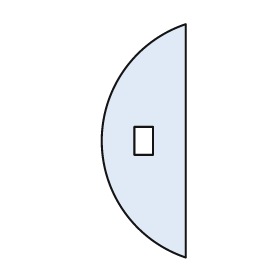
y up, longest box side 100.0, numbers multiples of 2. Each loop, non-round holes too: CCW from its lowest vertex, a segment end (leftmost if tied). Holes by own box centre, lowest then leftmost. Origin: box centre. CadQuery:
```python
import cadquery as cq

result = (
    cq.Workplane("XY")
    .moveTo(18.0, -50.0)
    .lineTo(18.0, 50.0)
    .threePointArc((-18.0, 0.0), (18.0, -50.0))
    .close()
    .moveTo(-4.0, -6.0)
    .lineTo(4.0, -6.0)
    .lineTo(4.0, 6.0)
    .lineTo(-4.0, 6.0)
    .close()
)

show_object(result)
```